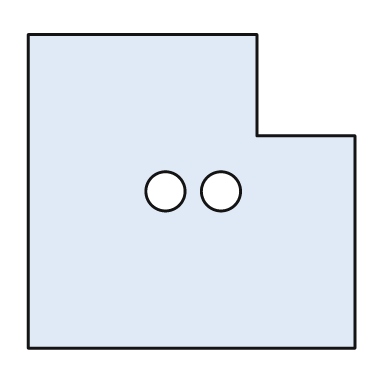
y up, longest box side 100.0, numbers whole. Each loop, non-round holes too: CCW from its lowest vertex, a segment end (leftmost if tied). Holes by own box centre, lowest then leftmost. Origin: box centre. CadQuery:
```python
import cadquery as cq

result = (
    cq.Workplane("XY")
    .moveTo(-50.0, -48.0)
    .lineTo(50.0, -48.0)
    .lineTo(50.0, 17.0)
    .lineTo(20.0, 17.0)
    .lineTo(20.0, 48.0)
    .lineTo(-50.0, 48.0)
    .close()
    .moveTo(-8.0, 0.0)
    .circle(6.0)
    .moveTo(9.0, 0.0)
    .circle(6.0)
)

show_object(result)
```